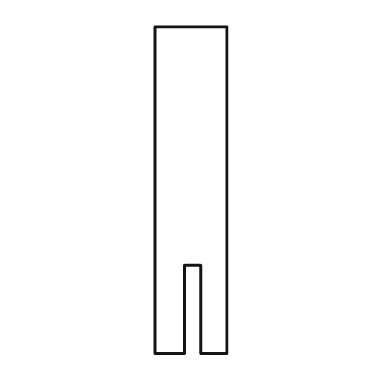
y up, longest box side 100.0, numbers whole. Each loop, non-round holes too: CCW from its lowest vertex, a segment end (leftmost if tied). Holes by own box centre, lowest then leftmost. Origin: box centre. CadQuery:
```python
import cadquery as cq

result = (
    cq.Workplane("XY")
    .moveTo(-11.0, -50.0)
    .lineTo(-2.0, -50.0)
    .lineTo(-2.0, -23.0)
    .lineTo(3.0, -23.0)
    .lineTo(3.0, -50.0)
    .lineTo(11.0, -50.0)
    .lineTo(11.0, 50.0)
    .lineTo(-11.0, 50.0)
    .close()
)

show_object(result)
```